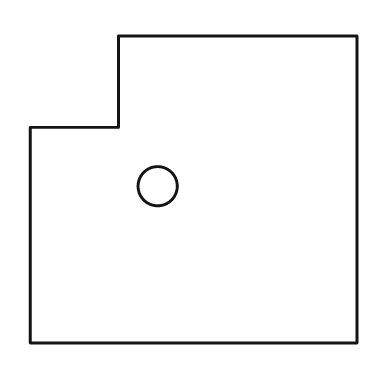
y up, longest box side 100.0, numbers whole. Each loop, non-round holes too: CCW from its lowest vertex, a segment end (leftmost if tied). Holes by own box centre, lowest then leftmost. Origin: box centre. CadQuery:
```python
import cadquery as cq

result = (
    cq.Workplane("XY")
    .moveTo(-50.0, -47.0)
    .lineTo(50.0, -47.0)
    .lineTo(50.0, 47.0)
    .lineTo(-23.0, 47.0)
    .lineTo(-23.0, 19.0)
    .lineTo(-50.0, 19.0)
    .close()
    .moveTo(-11.0, 1.0)
    .circle(6.0)
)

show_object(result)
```